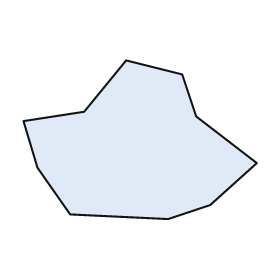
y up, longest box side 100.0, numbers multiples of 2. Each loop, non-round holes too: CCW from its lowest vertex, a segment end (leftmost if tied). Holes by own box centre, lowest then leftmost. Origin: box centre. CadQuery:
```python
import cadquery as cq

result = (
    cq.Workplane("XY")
    .moveTo(12.0, -34.0)
    .lineTo(30.0, -28.0)
    .lineTo(50.0, -10.0)
    .lineTo(24.0, 10.0)
    .lineTo(18.0, 28.0)
    .lineTo(-6.0, 34.0)
    .lineTo(-24.0, 12.0)
    .lineTo(-50.0, 8.0)
    .lineTo(-44.0, -12.0)
    .lineTo(-30.0, -32.0)
    .close()
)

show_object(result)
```